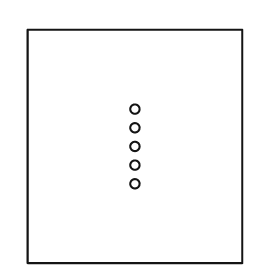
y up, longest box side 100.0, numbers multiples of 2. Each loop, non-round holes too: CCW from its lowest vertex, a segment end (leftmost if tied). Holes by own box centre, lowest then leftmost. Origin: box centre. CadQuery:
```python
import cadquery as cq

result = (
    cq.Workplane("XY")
    .moveTo(-46.0, -50.0)
    .lineTo(46.0, -50.0)
    .lineTo(46.0, 50.0)
    .lineTo(-46.0, 50.0)
    .close()
    .moveTo(0.0, -16.0)
    .circle(2.0)
    .moveTo(0.0, -8.0)
    .circle(2.0)
    .moveTo(0.0, 0.0)
    .circle(2.0)
    .moveTo(0.0, 8.0)
    .circle(2.0)
    .moveTo(0.0, 16.0)
    .circle(2.0)
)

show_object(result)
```